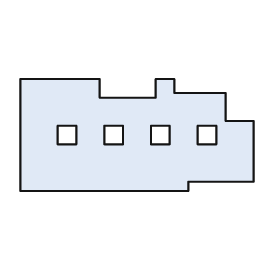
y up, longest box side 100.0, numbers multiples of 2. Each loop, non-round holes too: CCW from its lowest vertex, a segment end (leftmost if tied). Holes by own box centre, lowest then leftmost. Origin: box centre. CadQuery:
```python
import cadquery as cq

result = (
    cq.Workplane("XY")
    .moveTo(-50.0, -24.0)
    .lineTo(22.0, -24.0)
    .lineTo(22.0, -20.0)
    .lineTo(50.0, -20.0)
    .lineTo(50.0, 6.0)
    .lineTo(38.0, 6.0)
    .lineTo(38.0, 18.0)
    .lineTo(16.0, 18.0)
    .lineTo(16.0, 24.0)
    .lineTo(8.0, 24.0)
    .lineTo(8.0, 16.0)
    .lineTo(-16.0, 16.0)
    .lineTo(-16.0, 24.0)
    .lineTo(-50.0, 24.0)
    .close()
    .moveTo(-34.0, -4.0)
    .lineTo(-26.0, -4.0)
    .lineTo(-26.0, 4.0)
    .lineTo(-34.0, 4.0)
    .close()
    .moveTo(-14.0, -4.0)
    .lineTo(-6.0, -4.0)
    .lineTo(-6.0, 4.0)
    .lineTo(-14.0, 4.0)
    .close()
    .moveTo(6.0, -4.0)
    .lineTo(14.0, -4.0)
    .lineTo(14.0, 4.0)
    .lineTo(6.0, 4.0)
    .close()
    .moveTo(26.0, -4.0)
    .lineTo(34.0, -4.0)
    .lineTo(34.0, 4.0)
    .lineTo(26.0, 4.0)
    .close()
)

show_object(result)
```